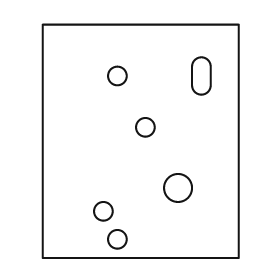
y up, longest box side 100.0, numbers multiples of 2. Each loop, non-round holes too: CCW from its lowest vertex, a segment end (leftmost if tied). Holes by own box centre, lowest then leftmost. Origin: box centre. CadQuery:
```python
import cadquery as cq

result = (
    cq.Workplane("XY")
    .moveTo(-42.0, -50.0)
    .lineTo(42.0, -50.0)
    .lineTo(42.0, 50.0)
    .lineTo(-42.0, 50.0)
    .close()
    .moveTo(-10.0, -42.0)
    .circle(4.0)
    .moveTo(-16.0, -30.0)
    .circle(4.0)
    .moveTo(16.0, -20.0)
    .circle(6.0)
    .moveTo(2.0, 6.0)
    .circle(4.0)
    .moveTo(-10.0, 28.0)
    .circle(4.0)
    .moveTo(22.0, 24.0)
    .threePointArc((26.0, 20.0), (30.0, 24.0))
    .lineTo(30.0, 32.0)
    .threePointArc((26.0, 36.0), (22.0, 32.0))
    .close()
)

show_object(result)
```